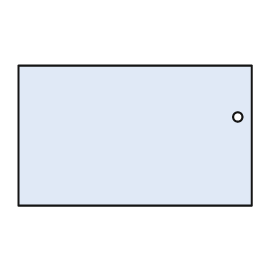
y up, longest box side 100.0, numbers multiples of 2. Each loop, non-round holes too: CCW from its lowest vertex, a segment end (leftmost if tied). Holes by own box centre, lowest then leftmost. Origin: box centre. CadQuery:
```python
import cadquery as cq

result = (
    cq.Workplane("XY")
    .moveTo(-50.0, -30.0)
    .lineTo(50.0, -30.0)
    .lineTo(50.0, 30.0)
    .lineTo(-50.0, 30.0)
    .close()
    .moveTo(44.0, 8.0)
    .circle(2.0)
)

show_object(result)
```